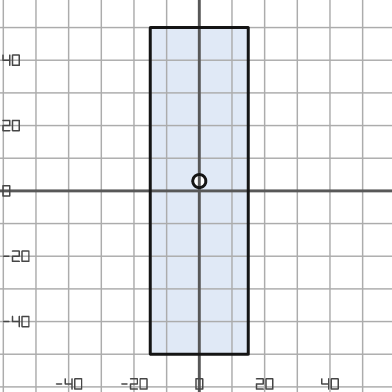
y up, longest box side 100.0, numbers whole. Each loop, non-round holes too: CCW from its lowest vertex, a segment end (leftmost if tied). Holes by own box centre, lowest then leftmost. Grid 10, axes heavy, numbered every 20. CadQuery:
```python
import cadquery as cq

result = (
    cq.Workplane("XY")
    .moveTo(-15.0, -50.0)
    .lineTo(15.0, -50.0)
    .lineTo(15.0, 50.0)
    .lineTo(-15.0, 50.0)
    .close()
    .moveTo(0.0, 3.0)
    .circle(2.0)
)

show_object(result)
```